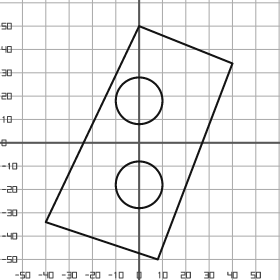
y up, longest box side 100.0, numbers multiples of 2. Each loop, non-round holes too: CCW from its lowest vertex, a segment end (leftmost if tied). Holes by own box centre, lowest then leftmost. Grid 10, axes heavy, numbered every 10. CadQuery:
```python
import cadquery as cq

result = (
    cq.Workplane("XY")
    .moveTo(8.0, -50.0)
    .lineTo(40.0, 34.0)
    .lineTo(0.0, 50.0)
    .lineTo(-40.0, -34.0)
    .close()
    .moveTo(0.0, -18.0)
    .circle(10.0)
    .moveTo(0.0, 18.0)
    .circle(10.0)
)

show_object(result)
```